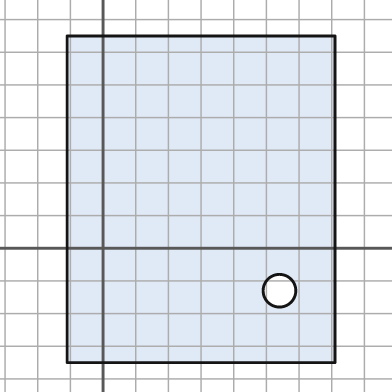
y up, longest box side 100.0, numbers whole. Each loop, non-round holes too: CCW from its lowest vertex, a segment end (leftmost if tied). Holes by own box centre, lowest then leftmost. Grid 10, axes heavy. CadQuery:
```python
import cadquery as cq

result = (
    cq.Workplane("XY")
    .moveTo(-11.0, -35.0)
    .lineTo(71.0, -35.0)
    .lineTo(71.0, 65.0)
    .lineTo(-11.0, 65.0)
    .close()
    .moveTo(54.0, -13.0)
    .circle(5.0)
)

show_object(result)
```